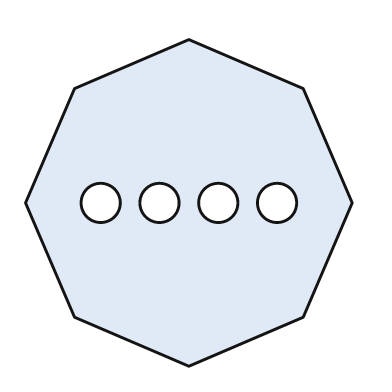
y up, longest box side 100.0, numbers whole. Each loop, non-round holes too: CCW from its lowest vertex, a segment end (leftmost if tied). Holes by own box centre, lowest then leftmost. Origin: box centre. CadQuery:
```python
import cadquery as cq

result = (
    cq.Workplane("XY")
    .moveTo(0.0, -50.0)
    .lineTo(35.0, -35.0)
    .lineTo(50.0, 0.0)
    .lineTo(35.0, 35.0)
    .lineTo(0.0, 50.0)
    .lineTo(-35.0, 35.0)
    .lineTo(-50.0, 0.0)
    .lineTo(-35.0, -35.0)
    .close()
    .moveTo(-27.0, 0.0)
    .circle(6.0)
    .moveTo(-9.0, 0.0)
    .circle(6.0)
    .moveTo(9.0, 0.0)
    .circle(6.0)
    .moveTo(27.0, 0.0)
    .circle(6.0)
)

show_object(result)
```